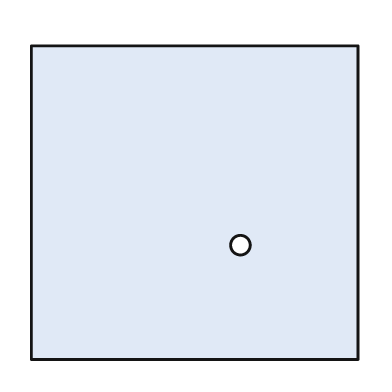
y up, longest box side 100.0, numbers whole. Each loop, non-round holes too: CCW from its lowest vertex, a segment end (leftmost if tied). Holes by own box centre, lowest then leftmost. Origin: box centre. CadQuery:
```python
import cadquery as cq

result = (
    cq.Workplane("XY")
    .moveTo(-50.0, -48.0)
    .lineTo(50.0, -48.0)
    .lineTo(50.0, 48.0)
    .lineTo(-50.0, 48.0)
    .close()
    .moveTo(14.0, -13.0)
    .circle(3.0)
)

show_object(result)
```